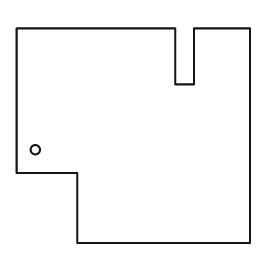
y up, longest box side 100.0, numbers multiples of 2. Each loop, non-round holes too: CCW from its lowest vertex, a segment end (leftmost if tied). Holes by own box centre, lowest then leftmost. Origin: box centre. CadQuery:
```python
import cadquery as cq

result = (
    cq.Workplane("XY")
    .moveTo(-24.0, -46.0)
    .lineTo(50.0, -46.0)
    .lineTo(50.0, 46.0)
    .lineTo(26.0, 46.0)
    .lineTo(26.0, 22.0)
    .lineTo(18.0, 22.0)
    .lineTo(18.0, 46.0)
    .lineTo(-50.0, 46.0)
    .lineTo(-50.0, -16.0)
    .lineTo(-24.0, -16.0)
    .close()
    .moveTo(-42.0, -6.0)
    .circle(2.0)
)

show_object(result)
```